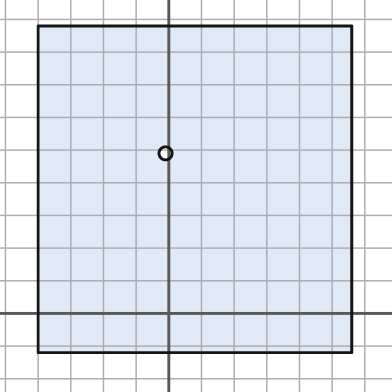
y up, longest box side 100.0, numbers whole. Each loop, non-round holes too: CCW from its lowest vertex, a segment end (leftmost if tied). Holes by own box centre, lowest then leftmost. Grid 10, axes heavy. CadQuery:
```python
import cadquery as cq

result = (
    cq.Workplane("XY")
    .moveTo(-40.0, -12.0)
    .lineTo(56.0, -12.0)
    .lineTo(56.0, 88.0)
    .lineTo(-40.0, 88.0)
    .close()
    .moveTo(-1.0, 49.0)
    .circle(2.0)
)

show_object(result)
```